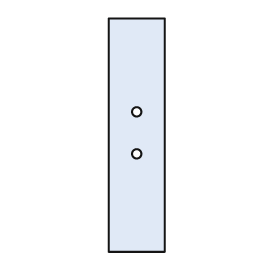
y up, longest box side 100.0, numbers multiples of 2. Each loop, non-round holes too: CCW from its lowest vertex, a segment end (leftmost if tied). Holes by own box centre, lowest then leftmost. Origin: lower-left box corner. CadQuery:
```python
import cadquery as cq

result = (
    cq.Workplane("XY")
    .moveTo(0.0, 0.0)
    .lineTo(24.0, 0.0)
    .lineTo(24.0, 100.0)
    .lineTo(0.0, 100.0)
    .close()
    .moveTo(12.0, 42.0)
    .circle(2.0)
    .moveTo(12.0, 60.0)
    .circle(2.0)
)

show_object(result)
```